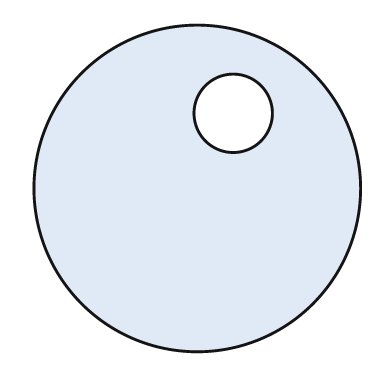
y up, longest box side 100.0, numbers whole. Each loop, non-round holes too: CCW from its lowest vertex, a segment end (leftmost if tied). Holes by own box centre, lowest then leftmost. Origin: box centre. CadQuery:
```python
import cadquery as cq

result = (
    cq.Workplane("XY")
    .moveTo(0.0, 0.0)
    .circle(50.0)
    .moveTo(11.0, 23.0)
    .circle(12.0)
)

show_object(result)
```